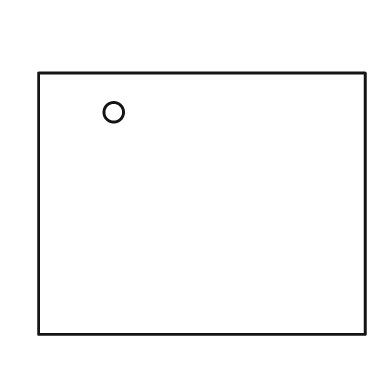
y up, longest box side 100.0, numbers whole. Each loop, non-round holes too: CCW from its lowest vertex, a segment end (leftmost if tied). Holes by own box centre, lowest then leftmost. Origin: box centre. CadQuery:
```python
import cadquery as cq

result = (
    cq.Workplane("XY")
    .moveTo(-50.0, -40.0)
    .lineTo(50.0, -40.0)
    .lineTo(50.0, 40.0)
    .lineTo(-50.0, 40.0)
    .close()
    .moveTo(-27.0, 28.0)
    .circle(3.0)
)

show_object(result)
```